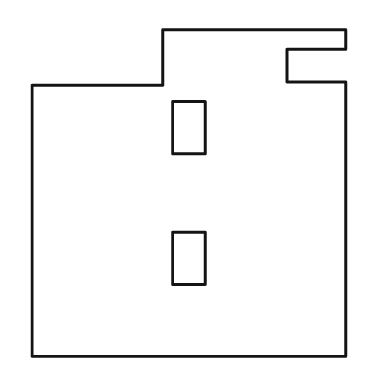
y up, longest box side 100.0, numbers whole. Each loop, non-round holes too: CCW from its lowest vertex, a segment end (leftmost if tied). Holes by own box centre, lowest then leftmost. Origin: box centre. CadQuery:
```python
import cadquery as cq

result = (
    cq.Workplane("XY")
    .moveTo(-48.0, -50.0)
    .lineTo(48.0, -50.0)
    .lineTo(48.0, 34.0)
    .lineTo(30.0, 34.0)
    .lineTo(30.0, 44.0)
    .lineTo(48.0, 44.0)
    .lineTo(48.0, 50.0)
    .lineTo(-8.0, 50.0)
    .lineTo(-8.0, 33.0)
    .lineTo(-48.0, 33.0)
    .close()
    .moveTo(-5.0, -28.0)
    .lineTo(5.0, -28.0)
    .lineTo(5.0, -12.0)
    .lineTo(-5.0, -12.0)
    .close()
    .moveTo(-5.0, 12.0)
    .lineTo(5.0, 12.0)
    .lineTo(5.0, 28.0)
    .lineTo(-5.0, 28.0)
    .close()
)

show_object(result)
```